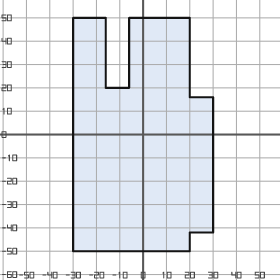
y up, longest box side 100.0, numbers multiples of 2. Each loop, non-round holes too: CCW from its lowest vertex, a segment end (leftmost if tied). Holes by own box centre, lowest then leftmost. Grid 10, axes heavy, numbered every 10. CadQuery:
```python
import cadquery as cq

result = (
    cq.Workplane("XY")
    .moveTo(-30.0, -50.0)
    .lineTo(20.0, -50.0)
    .lineTo(20.0, -42.0)
    .lineTo(30.0, -42.0)
    .lineTo(30.0, 16.0)
    .lineTo(20.0, 16.0)
    .lineTo(20.0, 50.0)
    .lineTo(-6.0, 50.0)
    .lineTo(-6.0, 20.0)
    .lineTo(-16.0, 20.0)
    .lineTo(-16.0, 50.0)
    .lineTo(-30.0, 50.0)
    .close()
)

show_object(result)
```